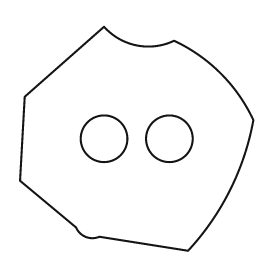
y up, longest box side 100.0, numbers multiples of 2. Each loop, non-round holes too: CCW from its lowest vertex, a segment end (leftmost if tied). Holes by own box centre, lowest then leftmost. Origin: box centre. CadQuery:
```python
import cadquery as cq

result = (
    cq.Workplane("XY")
    .moveTo(22.0, -48.0)
    .threePointArc((40.0, -22.0), (50.0, 8.0))
    .threePointArc((36.0, 28.0), (16.0, 42.0))
    .threePointArc((0.0, 40.0), (-14.0, 48.0))
    .lineTo(-48.0, 18.0)
    .lineTo(-50.0, -18.0)
    .lineTo(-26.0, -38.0)
    .threePointArc((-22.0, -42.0), (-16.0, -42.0))
    .close()
    .moveTo(-14.0, 0.0)
    .circle(10.0)
    .moveTo(14.0, 0.0)
    .circle(10.0)
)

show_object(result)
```